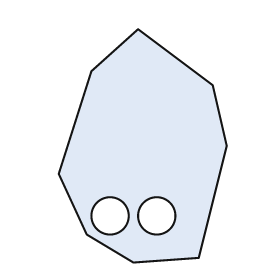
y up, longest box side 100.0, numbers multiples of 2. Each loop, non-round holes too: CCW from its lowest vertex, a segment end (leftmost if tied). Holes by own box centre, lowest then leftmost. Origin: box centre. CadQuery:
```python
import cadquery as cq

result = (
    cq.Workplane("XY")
    .moveTo(-4.0, -50.0)
    .lineTo(24.0, -48.0)
    .lineTo(36.0, 0.0)
    .lineTo(30.0, 26.0)
    .lineTo(-2.0, 50.0)
    .lineTo(-22.0, 32.0)
    .lineTo(-36.0, -12.0)
    .lineTo(-24.0, -38.0)
    .close()
    .moveTo(-14.0, -30.0)
    .circle(8.0)
    .moveTo(6.0, -30.0)
    .circle(8.0)
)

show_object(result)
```